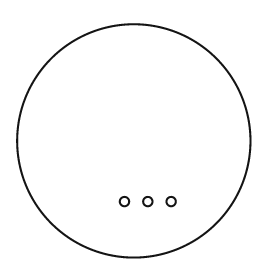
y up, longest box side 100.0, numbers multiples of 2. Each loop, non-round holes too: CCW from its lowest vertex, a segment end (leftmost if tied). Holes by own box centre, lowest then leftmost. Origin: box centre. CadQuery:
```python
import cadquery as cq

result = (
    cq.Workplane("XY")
    .moveTo(0.0, 0.0)
    .circle(50.0)
    .moveTo(-4.0, -26.0)
    .circle(2.0)
    .moveTo(6.0, -26.0)
    .circle(2.0)
    .moveTo(16.0, -26.0)
    .circle(2.0)
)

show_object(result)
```